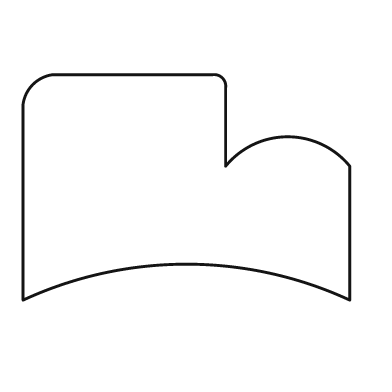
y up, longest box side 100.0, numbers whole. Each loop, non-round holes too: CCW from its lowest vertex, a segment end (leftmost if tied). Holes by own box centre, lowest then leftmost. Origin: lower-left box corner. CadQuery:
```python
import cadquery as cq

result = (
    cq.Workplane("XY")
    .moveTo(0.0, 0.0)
    .threePointArc((50.0, 11.0), (100.0, 0.0))
    .lineTo(100.0, 41.0)
    .threePointArc((81.0, 50.0), (62.0, 41.0))
    .lineTo(62.0, 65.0)
    .threePointArc((61.0, 68.0), (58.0, 69.0))
    .lineTo(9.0, 69.0)
    .threePointArc((3.0, 66.0), (0.0, 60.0))
    .close()
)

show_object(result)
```